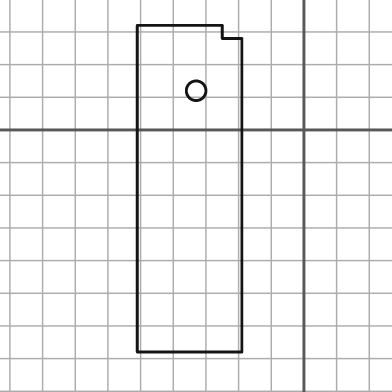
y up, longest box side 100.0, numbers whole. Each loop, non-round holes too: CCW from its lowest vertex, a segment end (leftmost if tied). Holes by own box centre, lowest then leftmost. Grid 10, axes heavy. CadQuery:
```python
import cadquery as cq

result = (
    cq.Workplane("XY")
    .moveTo(-51.0, -68.0)
    .lineTo(-19.0, -68.0)
    .lineTo(-19.0, 28.0)
    .lineTo(-25.0, 28.0)
    .lineTo(-25.0, 32.0)
    .lineTo(-51.0, 32.0)
    .close()
    .moveTo(-33.0, 12.0)
    .circle(3.0)
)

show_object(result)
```